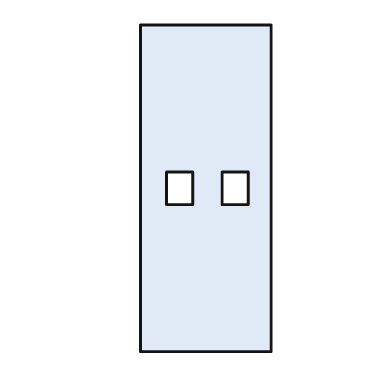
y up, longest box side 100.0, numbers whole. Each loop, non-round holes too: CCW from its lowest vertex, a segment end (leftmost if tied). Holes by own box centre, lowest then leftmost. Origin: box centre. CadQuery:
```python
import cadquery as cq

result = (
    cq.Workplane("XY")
    .moveTo(-20.0, -50.0)
    .lineTo(20.0, -50.0)
    .lineTo(20.0, 50.0)
    .lineTo(-20.0, 50.0)
    .close()
    .moveTo(-12.0, -5.0)
    .lineTo(-4.0, -5.0)
    .lineTo(-4.0, 5.0)
    .lineTo(-12.0, 5.0)
    .close()
    .moveTo(5.0, -5.0)
    .lineTo(13.0, -5.0)
    .lineTo(13.0, 5.0)
    .lineTo(5.0, 5.0)
    .close()
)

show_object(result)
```